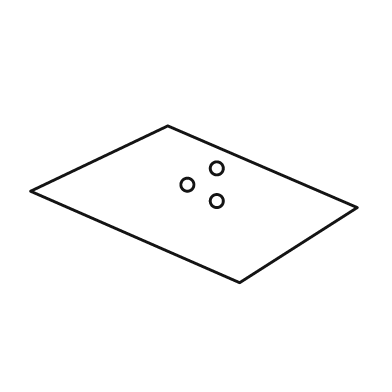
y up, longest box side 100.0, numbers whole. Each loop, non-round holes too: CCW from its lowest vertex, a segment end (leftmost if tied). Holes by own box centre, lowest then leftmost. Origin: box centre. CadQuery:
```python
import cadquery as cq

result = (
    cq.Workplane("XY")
    .moveTo(14.0, -24.0)
    .lineTo(50.0, -1.0)
    .lineTo(-8.0, 24.0)
    .lineTo(-50.0, 4.0)
    .close()
    .moveTo(7.0, 1.0)
    .circle(2.0)
    .moveTo(-2.0, 6.0)
    .circle(2.0)
    .moveTo(7.0, 11.0)
    .circle(2.0)
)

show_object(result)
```